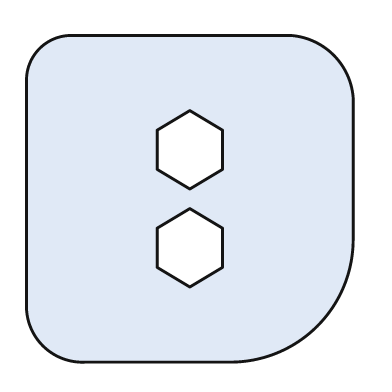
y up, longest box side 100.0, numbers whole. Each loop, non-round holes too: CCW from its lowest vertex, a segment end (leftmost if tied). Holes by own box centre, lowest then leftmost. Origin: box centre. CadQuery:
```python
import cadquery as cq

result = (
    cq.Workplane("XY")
    .moveTo(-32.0, -50.0)
    .lineTo(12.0, -50.0)
    .threePointArc((39.0, -39.0), (50.0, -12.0))
    .lineTo(50.0, 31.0)
    .threePointArc((44.0, 44.0), (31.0, 50.0))
    .lineTo(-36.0, 50.0)
    .threePointArc((-46.0, 46.0), (-50.0, 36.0))
    .lineTo(-50.0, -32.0)
    .threePointArc((-45.0, -45.0), (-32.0, -50.0))
    .close()
    .moveTo(0.0, -27.0)
    .lineTo(10.0, -21.0)
    .lineTo(10.0, -9.0)
    .lineTo(0.0, -3.0)
    .lineTo(-10.0, -9.0)
    .lineTo(-10.0, -21.0)
    .close()
    .moveTo(0.0, 3.0)
    .lineTo(10.0, 9.0)
    .lineTo(10.0, 21.0)
    .lineTo(0.0, 27.0)
    .lineTo(-10.0, 21.0)
    .lineTo(-10.0, 9.0)
    .close()
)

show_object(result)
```